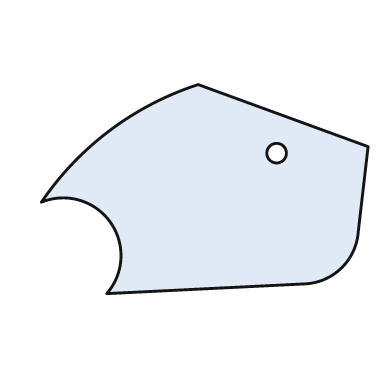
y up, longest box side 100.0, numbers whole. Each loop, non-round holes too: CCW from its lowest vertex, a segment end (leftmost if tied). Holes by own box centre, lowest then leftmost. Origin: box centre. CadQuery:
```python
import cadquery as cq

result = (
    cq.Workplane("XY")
    .moveTo(-30.0, -32.0)
    .lineTo(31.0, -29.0)
    .threePointArc((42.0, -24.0), (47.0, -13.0))
    .lineTo(50.0, 13.0)
    .lineTo(-2.0, 32.0)
    .threePointArc((-29.0, 18.0), (-50.0, -4.0))
    .threePointArc((-29.0, -10.0), (-30.0, -32.0))
    .close()
    .moveTo(22.0, 11.0)
    .circle(3.0)
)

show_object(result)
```